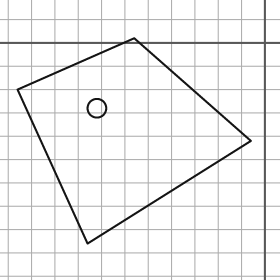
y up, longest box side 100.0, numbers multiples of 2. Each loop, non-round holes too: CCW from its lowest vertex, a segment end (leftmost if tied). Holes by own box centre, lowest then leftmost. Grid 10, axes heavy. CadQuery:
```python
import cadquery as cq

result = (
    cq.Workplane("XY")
    .moveTo(-76.0, -86.0)
    .lineTo(-6.0, -42.0)
    .lineTo(-56.0, 2.0)
    .lineTo(-106.0, -20.0)
    .close()
    .moveTo(-72.0, -28.0)
    .circle(4.0)
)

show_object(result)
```